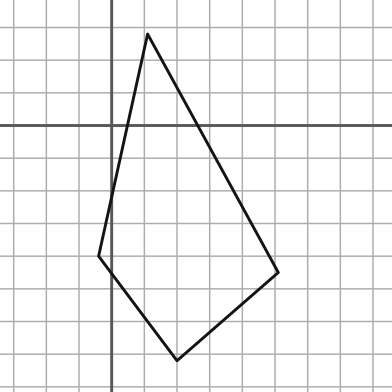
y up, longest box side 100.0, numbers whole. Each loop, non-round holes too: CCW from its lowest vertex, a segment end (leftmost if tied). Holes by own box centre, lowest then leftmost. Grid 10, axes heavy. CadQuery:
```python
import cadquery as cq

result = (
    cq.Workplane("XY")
    .moveTo(20.0, -72.0)
    .lineTo(51.0, -45.0)
    .lineTo(11.0, 28.0)
    .lineTo(-4.0, -40.0)
    .close()
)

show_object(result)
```